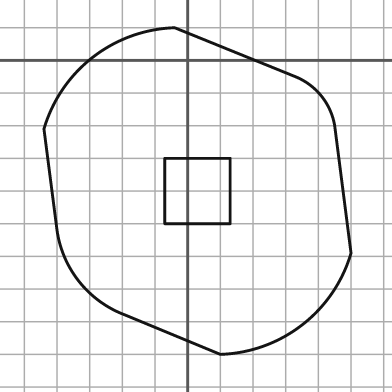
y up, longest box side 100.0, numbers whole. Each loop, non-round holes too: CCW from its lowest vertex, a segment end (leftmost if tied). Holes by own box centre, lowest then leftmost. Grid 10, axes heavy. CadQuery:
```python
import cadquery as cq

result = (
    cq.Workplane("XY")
    .moveTo(10.0, -90.0)
    .threePointArc((35.0, -81.0), (50.0, -59.0))
    .lineTo(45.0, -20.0)
    .threePointArc((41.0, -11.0), (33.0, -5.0))
    .lineTo(-4.0, 10.0)
    .threePointArc((-29.0, 1.0), (-44.0, -21.0))
    .lineTo(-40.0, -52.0)
    .threePointArc((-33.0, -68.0), (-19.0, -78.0))
    .close()
    .moveTo(-7.0, -50.0)
    .lineTo(13.0, -50.0)
    .lineTo(13.0, -30.0)
    .lineTo(-7.0, -30.0)
    .close()
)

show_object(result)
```